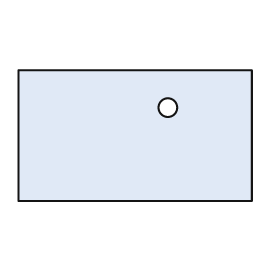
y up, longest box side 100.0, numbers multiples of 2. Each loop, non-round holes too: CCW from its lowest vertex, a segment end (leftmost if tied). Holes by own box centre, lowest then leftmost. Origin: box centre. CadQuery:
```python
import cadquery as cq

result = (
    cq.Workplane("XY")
    .moveTo(-50.0, -28.0)
    .lineTo(50.0, -28.0)
    .lineTo(50.0, 28.0)
    .lineTo(-50.0, 28.0)
    .close()
    .moveTo(14.0, 12.0)
    .circle(4.0)
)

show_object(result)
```